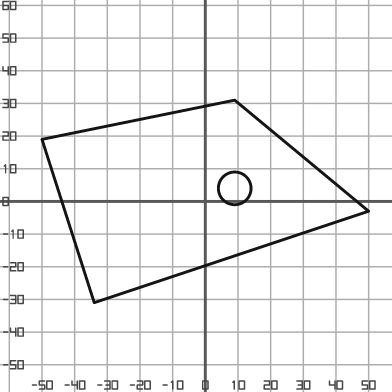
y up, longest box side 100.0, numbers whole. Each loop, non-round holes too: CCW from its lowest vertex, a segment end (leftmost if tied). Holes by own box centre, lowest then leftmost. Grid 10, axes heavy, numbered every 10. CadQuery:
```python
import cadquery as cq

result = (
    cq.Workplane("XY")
    .moveTo(-34.0, -31.0)
    .lineTo(50.0, -3.0)
    .lineTo(9.0, 31.0)
    .lineTo(-50.0, 19.0)
    .close()
    .moveTo(9.0, 4.0)
    .circle(5.0)
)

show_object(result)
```